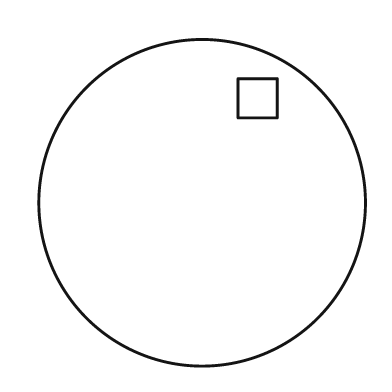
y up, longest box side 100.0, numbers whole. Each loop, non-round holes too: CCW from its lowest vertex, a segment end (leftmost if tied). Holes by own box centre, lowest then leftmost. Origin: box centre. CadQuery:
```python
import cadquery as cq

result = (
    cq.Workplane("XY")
    .moveTo(0.0, 0.0)
    .circle(50.0)
    .moveTo(11.0, 26.0)
    .lineTo(23.0, 26.0)
    .lineTo(23.0, 38.0)
    .lineTo(11.0, 38.0)
    .close()
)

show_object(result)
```